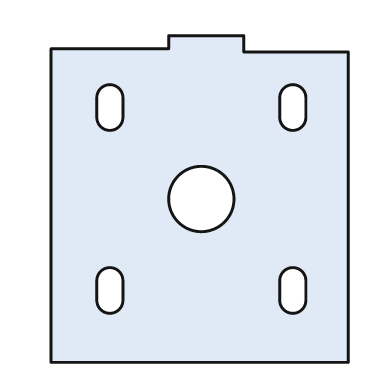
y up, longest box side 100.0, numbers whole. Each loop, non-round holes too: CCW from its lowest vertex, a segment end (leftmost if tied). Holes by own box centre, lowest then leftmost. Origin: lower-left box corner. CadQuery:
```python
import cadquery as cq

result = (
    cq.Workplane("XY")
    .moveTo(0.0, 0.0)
    .lineTo(91.0, 0.0)
    .lineTo(91.0, 95.0)
    .lineTo(59.0, 95.0)
    .lineTo(59.0, 100.0)
    .lineTo(36.0, 100.0)
    .lineTo(36.0, 96.0)
    .lineTo(0.0, 96.0)
    .close()
    .moveTo(14.0, 19.0)
    .threePointArc((18.0, 15.0), (22.0, 19.0))
    .lineTo(22.0, 25.0)
    .threePointArc((18.0, 29.0), (14.0, 25.0))
    .close()
    .moveTo(70.0, 19.0)
    .threePointArc((74.0, 15.0), (78.0, 19.0))
    .lineTo(78.0, 25.0)
    .threePointArc((74.0, 29.0), (70.0, 25.0))
    .close()
    .moveTo(46.0, 50.0)
    .circle(10.0)
    .moveTo(14.0, 75.0)
    .threePointArc((18.0, 71.0), (22.0, 75.0))
    .lineTo(22.0, 81.0)
    .threePointArc((18.0, 85.0), (14.0, 81.0))
    .close()
    .moveTo(70.0, 75.0)
    .threePointArc((74.0, 71.0), (78.0, 75.0))
    .lineTo(78.0, 81.0)
    .threePointArc((74.0, 85.0), (70.0, 81.0))
    .close()
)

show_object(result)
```